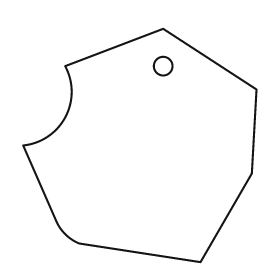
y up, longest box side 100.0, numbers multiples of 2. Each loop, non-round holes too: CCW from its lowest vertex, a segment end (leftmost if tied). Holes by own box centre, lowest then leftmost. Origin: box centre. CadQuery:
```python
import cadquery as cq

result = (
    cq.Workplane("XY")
    .moveTo(26.0, -50.0)
    .lineTo(48.0, -12.0)
    .lineTo(50.0, 24.0)
    .lineTo(10.0, 50.0)
    .lineTo(-32.0, 34.0)
    .threePointArc((-32.0, 12.0), (-50.0, 0.0))
    .lineTo(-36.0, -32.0)
    .threePointArc((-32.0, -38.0), (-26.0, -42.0))
    .close()
    .moveTo(10.0, 34.0)
    .circle(4.0)
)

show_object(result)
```